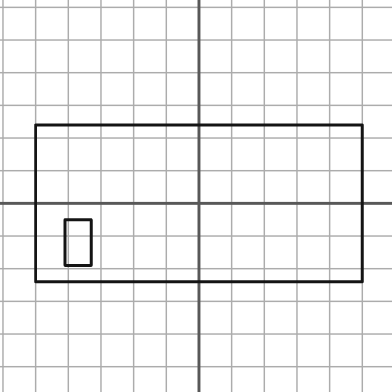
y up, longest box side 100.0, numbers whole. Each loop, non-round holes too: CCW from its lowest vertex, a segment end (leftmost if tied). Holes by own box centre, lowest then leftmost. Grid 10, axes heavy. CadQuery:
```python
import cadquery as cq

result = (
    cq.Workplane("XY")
    .moveTo(-50.0, -24.0)
    .lineTo(50.0, -24.0)
    .lineTo(50.0, 24.0)
    .lineTo(-50.0, 24.0)
    .close()
    .moveTo(-41.0, -19.0)
    .lineTo(-33.0, -19.0)
    .lineTo(-33.0, -5.0)
    .lineTo(-41.0, -5.0)
    .close()
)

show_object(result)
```